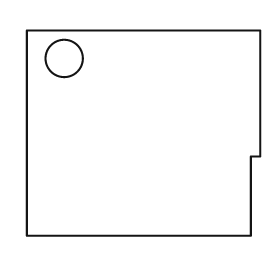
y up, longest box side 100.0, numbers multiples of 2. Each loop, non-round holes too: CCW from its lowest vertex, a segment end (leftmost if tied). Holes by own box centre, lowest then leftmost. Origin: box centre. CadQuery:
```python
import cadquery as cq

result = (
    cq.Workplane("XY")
    .moveTo(-50.0, -44.0)
    .lineTo(46.0, -44.0)
    .lineTo(46.0, -10.0)
    .lineTo(50.0, -10.0)
    .lineTo(50.0, 44.0)
    .lineTo(-50.0, 44.0)
    .close()
    .moveTo(-34.0, 32.0)
    .circle(8.0)
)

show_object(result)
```